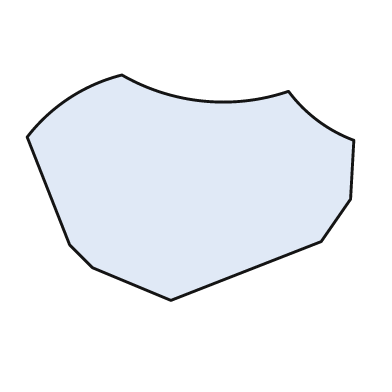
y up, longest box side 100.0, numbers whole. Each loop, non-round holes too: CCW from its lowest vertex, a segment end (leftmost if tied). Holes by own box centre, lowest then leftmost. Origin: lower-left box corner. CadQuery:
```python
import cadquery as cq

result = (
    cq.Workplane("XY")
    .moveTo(44.0, 0.0)
    .lineTo(90.0, 18.0)
    .lineTo(99.0, 31.0)
    .lineTo(100.0, 49.0)
    .threePointArc((89.0, 55.0), (80.0, 64.0))
    .threePointArc((54.0, 61.0), (29.0, 69.0))
    .threePointArc((13.0, 62.0), (0.0, 50.0))
    .lineTo(13.0, 17.0)
    .lineTo(20.0, 10.0)
    .close()
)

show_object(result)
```